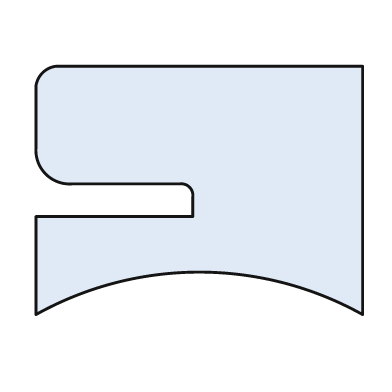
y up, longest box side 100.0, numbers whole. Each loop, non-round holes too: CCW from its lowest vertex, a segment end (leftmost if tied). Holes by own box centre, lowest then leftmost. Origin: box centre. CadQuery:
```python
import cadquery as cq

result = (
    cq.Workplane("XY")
    .moveTo(-50.0, -38.0)
    .threePointArc((0.0, -25.0), (50.0, -38.0))
    .lineTo(50.0, 38.0)
    .lineTo(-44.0, 38.0)
    .threePointArc((-48.0, 36.0), (-50.0, 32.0))
    .lineTo(-50.0, 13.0)
    .threePointArc((-47.0, 5.0), (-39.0, 2.0))
    .lineTo(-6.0, 2.0)
    .threePointArc((-3.0, 1.0), (-2.0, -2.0))
    .lineTo(-2.0, -8.0)
    .lineTo(-50.0, -8.0)
    .close()
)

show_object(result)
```